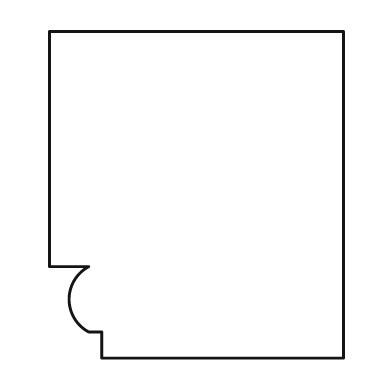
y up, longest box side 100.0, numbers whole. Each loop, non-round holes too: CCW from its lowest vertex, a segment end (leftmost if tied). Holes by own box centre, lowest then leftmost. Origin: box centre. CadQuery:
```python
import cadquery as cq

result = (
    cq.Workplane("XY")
    .moveTo(-29.0, -50.0)
    .lineTo(45.0, -50.0)
    .lineTo(45.0, 50.0)
    .lineTo(-45.0, 50.0)
    .lineTo(-45.0, -22.0)
    .lineTo(-33.0, -22.0)
    .threePointArc((-39.0, -32.0), (-33.0, -42.0))
    .lineTo(-29.0, -42.0)
    .close()
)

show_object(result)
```